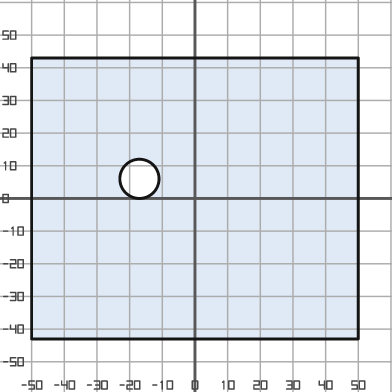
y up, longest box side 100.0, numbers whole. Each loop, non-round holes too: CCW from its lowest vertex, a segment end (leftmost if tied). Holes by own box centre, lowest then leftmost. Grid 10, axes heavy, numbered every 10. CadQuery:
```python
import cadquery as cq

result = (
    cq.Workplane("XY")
    .moveTo(-50.0, -43.0)
    .lineTo(50.0, -43.0)
    .lineTo(50.0, 43.0)
    .lineTo(-50.0, 43.0)
    .close()
    .moveTo(-17.0, 6.0)
    .circle(6.0)
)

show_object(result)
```